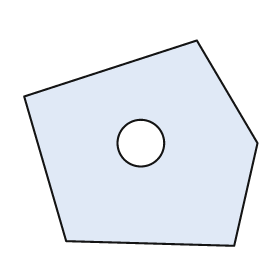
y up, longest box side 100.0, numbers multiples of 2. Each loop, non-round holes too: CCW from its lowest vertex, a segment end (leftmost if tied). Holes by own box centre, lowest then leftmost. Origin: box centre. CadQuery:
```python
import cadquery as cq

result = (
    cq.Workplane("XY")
    .moveTo(40.0, -44.0)
    .lineTo(50.0, 0.0)
    .lineTo(24.0, 44.0)
    .lineTo(-50.0, 20.0)
    .lineTo(-32.0, -42.0)
    .close()
    .moveTo(0.0, 0.0)
    .circle(10.0)
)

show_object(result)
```